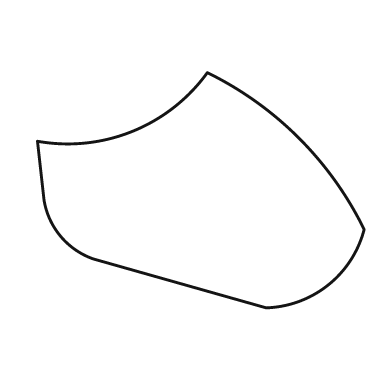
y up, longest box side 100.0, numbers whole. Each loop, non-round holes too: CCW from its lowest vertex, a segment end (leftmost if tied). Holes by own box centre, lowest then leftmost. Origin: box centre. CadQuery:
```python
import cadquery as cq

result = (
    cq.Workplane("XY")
    .moveTo(20.0, -36.0)
    .threePointArc((39.0, -29.0), (50.0, -12.0))
    .threePointArc((30.0, 16.0), (2.0, 36.0))
    .threePointArc((-21.0, 18.0), (-50.0, 15.0))
    .lineTo(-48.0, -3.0)
    .threePointArc((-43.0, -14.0), (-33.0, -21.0))
    .close()
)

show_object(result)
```